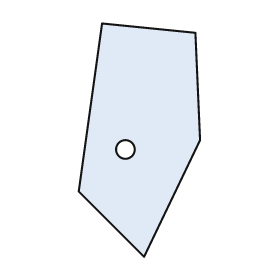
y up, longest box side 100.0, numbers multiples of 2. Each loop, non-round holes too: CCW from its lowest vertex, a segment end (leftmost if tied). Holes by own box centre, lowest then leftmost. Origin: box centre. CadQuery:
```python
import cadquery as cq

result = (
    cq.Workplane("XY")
    .moveTo(2.0, -50.0)
    .lineTo(26.0, 0.0)
    .lineTo(24.0, 46.0)
    .lineTo(-16.0, 50.0)
    .lineTo(-26.0, -22.0)
    .close()
    .moveTo(-6.0, -4.0)
    .circle(4.0)
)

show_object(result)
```